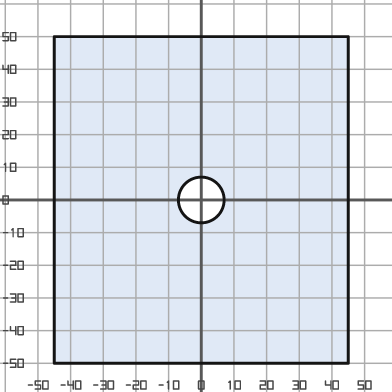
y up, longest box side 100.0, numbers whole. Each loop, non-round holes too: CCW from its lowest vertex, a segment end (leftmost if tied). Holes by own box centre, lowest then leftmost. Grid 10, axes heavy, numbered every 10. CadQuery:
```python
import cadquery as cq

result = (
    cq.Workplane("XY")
    .moveTo(-45.0, -50.0)
    .lineTo(45.0, -50.0)
    .lineTo(45.0, 50.0)
    .lineTo(-45.0, 50.0)
    .close()
    .moveTo(0.0, 0.0)
    .circle(7.0)
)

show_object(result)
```